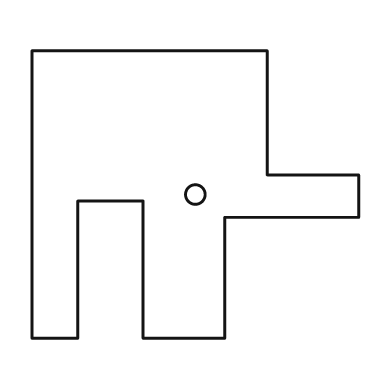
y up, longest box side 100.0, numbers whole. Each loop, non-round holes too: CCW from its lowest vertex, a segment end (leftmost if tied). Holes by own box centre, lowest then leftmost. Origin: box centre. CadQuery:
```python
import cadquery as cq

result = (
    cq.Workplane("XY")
    .moveTo(-50.0, -44.0)
    .lineTo(-36.0, -44.0)
    .lineTo(-36.0, -2.0)
    .lineTo(-16.0, -2.0)
    .lineTo(-16.0, -44.0)
    .lineTo(9.0, -44.0)
    .lineTo(9.0, -7.0)
    .lineTo(50.0, -7.0)
    .lineTo(50.0, 6.0)
    .lineTo(22.0, 6.0)
    .lineTo(22.0, 44.0)
    .lineTo(-50.0, 44.0)
    .close()
    .moveTo(0.0, 0.0)
    .circle(3.0)
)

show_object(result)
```